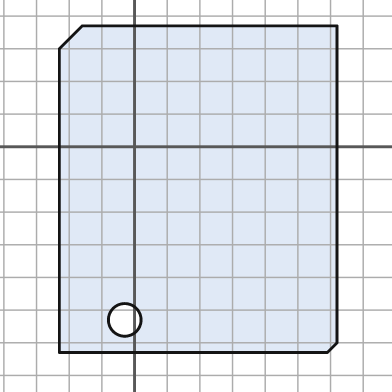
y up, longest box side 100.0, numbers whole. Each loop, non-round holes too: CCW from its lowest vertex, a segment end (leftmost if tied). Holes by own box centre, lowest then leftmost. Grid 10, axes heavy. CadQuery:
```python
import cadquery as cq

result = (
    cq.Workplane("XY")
    .moveTo(-23.0, -63.0)
    .lineTo(59.0, -63.0)
    .lineTo(62.0, -60.0)
    .lineTo(62.0, 37.0)
    .lineTo(-16.0, 37.0)
    .lineTo(-23.0, 30.0)
    .close()
    .moveTo(-3.0, -53.0)
    .circle(5.0)
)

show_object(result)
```